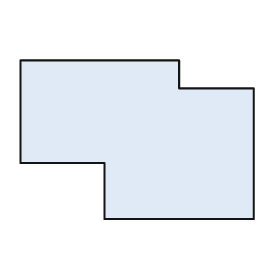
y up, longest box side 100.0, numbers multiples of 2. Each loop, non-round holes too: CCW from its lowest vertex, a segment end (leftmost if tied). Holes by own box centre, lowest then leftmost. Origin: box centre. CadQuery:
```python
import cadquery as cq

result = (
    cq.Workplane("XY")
    .moveTo(-14.0, -34.0)
    .lineTo(50.0, -34.0)
    .lineTo(50.0, 22.0)
    .lineTo(18.0, 22.0)
    .lineTo(18.0, 34.0)
    .lineTo(-50.0, 34.0)
    .lineTo(-50.0, -10.0)
    .lineTo(-14.0, -10.0)
    .close()
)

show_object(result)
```